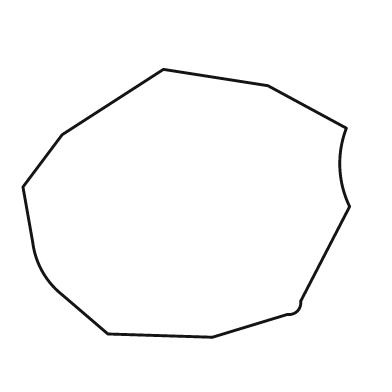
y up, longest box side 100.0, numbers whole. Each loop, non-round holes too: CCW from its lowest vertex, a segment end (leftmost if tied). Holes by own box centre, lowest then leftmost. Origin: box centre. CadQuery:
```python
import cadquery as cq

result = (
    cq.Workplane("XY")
    .moveTo(8.0, -41.0)
    .lineTo(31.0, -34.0)
    .threePointArc((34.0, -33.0), (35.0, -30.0))
    .lineTo(50.0, -1.0)
    .threePointArc((47.0, 11.0), (49.0, 23.0))
    .lineTo(25.0, 36.0)
    .lineTo(-7.0, 41.0)
    .lineTo(-38.0, 21.0)
    .lineTo(-50.0, 5.0)
    .lineTo(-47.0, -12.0)
    .threePointArc((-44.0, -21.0), (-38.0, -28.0))
    .lineTo(-24.0, -40.0)
    .close()
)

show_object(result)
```